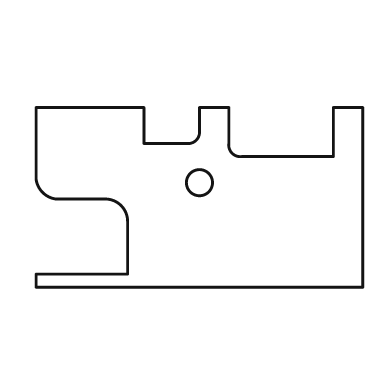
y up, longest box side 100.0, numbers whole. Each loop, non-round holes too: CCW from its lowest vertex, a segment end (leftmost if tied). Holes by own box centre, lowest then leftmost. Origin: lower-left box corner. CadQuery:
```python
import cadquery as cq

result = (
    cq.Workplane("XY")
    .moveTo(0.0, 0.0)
    .lineTo(100.0, 0.0)
    .lineTo(100.0, 55.0)
    .lineTo(91.0, 55.0)
    .lineTo(91.0, 40.0)
    .lineTo(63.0, 40.0)
    .threePointArc((60.0, 41.0), (59.0, 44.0))
    .lineTo(59.0, 55.0)
    .lineTo(50.0, 55.0)
    .lineTo(50.0, 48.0)
    .threePointArc((49.0, 45.0), (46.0, 44.0))
    .lineTo(33.0, 44.0)
    .lineTo(33.0, 55.0)
    .lineTo(0.0, 55.0)
    .lineTo(0.0, 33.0)
    .threePointArc((2.0, 29.0), (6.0, 27.0))
    .lineTo(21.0, 27.0)
    .threePointArc((26.0, 25.0), (28.0, 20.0))
    .lineTo(28.0, 4.0)
    .lineTo(0.0, 4.0)
    .close()
    .moveTo(50.0, 32.0)
    .circle(4.0)
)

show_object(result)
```